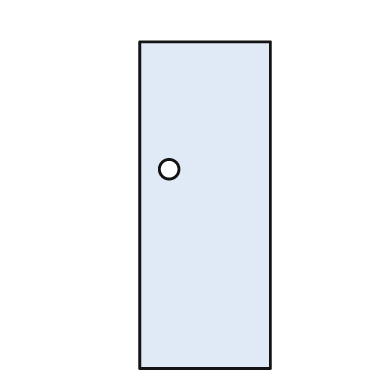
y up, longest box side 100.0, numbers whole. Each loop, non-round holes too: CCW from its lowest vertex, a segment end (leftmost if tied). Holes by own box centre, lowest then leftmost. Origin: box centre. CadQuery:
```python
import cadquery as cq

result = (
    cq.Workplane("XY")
    .moveTo(-20.0, -50.0)
    .lineTo(20.0, -50.0)
    .lineTo(20.0, 50.0)
    .lineTo(-20.0, 50.0)
    .close()
    .moveTo(-11.0, 11.0)
    .circle(3.0)
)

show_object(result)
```